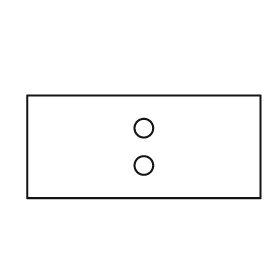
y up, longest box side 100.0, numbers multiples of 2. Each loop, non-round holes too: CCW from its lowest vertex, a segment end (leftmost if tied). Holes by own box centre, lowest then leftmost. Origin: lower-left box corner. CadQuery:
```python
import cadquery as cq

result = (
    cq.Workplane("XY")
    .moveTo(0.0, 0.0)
    .lineTo(100.0, 0.0)
    .lineTo(100.0, 44.0)
    .lineTo(0.0, 44.0)
    .close()
    .moveTo(50.0, 14.0)
    .circle(4.0)
    .moveTo(50.0, 30.0)
    .circle(4.0)
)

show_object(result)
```